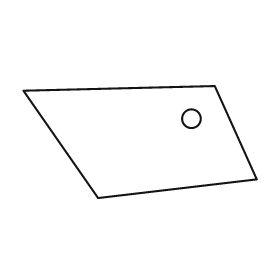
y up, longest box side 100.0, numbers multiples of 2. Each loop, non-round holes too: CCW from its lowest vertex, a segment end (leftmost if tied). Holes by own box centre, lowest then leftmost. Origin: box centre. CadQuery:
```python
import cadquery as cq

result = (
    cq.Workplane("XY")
    .moveTo(-18.0, -24.0)
    .lineTo(50.0, -16.0)
    .lineTo(32.0, 24.0)
    .lineTo(-50.0, 22.0)
    .close()
    .moveTo(22.0, 10.0)
    .circle(4.0)
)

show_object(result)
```